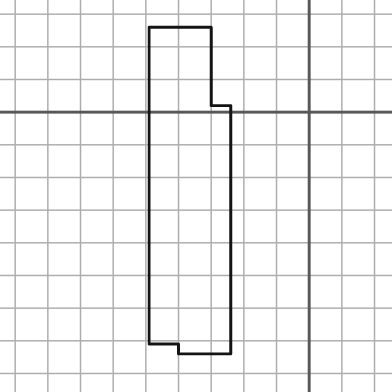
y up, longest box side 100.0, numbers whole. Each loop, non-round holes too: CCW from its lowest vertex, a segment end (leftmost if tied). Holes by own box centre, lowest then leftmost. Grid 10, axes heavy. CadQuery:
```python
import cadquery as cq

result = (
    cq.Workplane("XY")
    .moveTo(-40.0, -74.0)
    .lineTo(-24.0, -74.0)
    .lineTo(-24.0, 2.0)
    .lineTo(-30.0, 2.0)
    .lineTo(-30.0, 26.0)
    .lineTo(-49.0, 26.0)
    .lineTo(-49.0, -71.0)
    .lineTo(-40.0, -71.0)
    .close()
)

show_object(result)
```